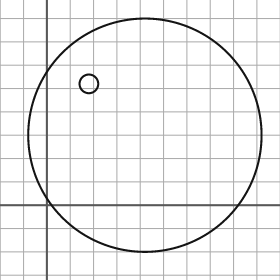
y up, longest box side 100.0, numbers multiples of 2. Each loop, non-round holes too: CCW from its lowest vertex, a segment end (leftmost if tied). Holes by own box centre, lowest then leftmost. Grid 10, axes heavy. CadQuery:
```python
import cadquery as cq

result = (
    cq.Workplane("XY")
    .moveTo(42.0, 30.0)
    .circle(50.0)
    .moveTo(18.0, 52.0)
    .circle(4.0)
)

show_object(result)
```